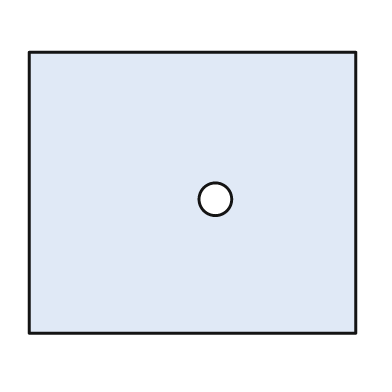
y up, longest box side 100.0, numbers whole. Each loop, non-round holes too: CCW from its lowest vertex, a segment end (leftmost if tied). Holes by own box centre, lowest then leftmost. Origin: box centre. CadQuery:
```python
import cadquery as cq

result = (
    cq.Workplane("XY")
    .moveTo(-50.0, -43.0)
    .lineTo(50.0, -43.0)
    .lineTo(50.0, 43.0)
    .lineTo(-50.0, 43.0)
    .close()
    .moveTo(7.0, -2.0)
    .circle(5.0)
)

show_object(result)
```